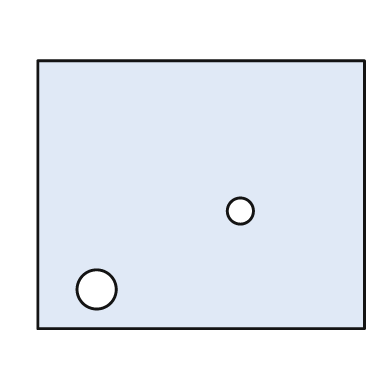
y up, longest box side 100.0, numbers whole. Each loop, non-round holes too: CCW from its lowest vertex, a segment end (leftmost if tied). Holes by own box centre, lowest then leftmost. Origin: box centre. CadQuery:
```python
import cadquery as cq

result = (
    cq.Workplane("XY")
    .moveTo(-50.0, -41.0)
    .lineTo(50.0, -41.0)
    .lineTo(50.0, 41.0)
    .lineTo(-50.0, 41.0)
    .close()
    .moveTo(-32.0, -29.0)
    .circle(6.0)
    .moveTo(12.0, -5.0)
    .circle(4.0)
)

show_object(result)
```